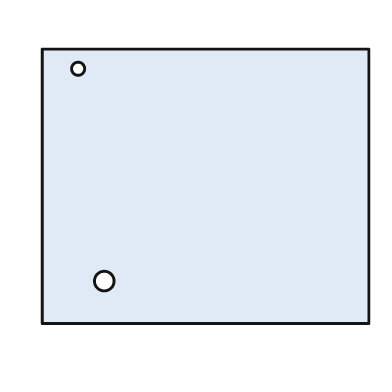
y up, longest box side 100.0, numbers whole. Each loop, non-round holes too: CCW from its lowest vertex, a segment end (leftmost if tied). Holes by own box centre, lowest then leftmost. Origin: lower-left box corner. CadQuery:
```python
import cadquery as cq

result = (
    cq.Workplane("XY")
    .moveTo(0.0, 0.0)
    .lineTo(100.0, 0.0)
    .lineTo(100.0, 84.0)
    .lineTo(0.0, 84.0)
    .close()
    .moveTo(19.0, 13.0)
    .circle(3.0)
    .moveTo(11.0, 78.0)
    .circle(2.0)
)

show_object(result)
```